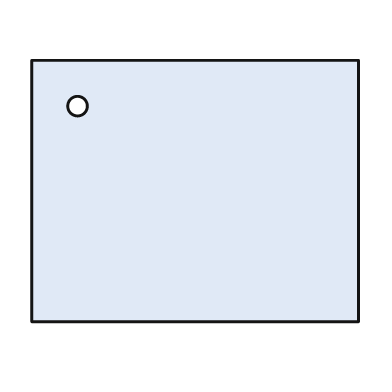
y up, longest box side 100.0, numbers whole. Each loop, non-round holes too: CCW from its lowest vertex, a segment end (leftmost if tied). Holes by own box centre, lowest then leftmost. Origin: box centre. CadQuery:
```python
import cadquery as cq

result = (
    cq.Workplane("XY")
    .moveTo(-50.0, -40.0)
    .lineTo(50.0, -40.0)
    .lineTo(50.0, 40.0)
    .lineTo(-50.0, 40.0)
    .close()
    .moveTo(-36.0, 26.0)
    .circle(3.0)
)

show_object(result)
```